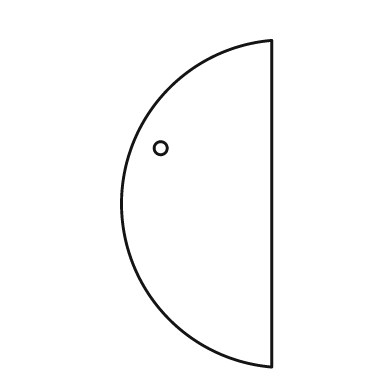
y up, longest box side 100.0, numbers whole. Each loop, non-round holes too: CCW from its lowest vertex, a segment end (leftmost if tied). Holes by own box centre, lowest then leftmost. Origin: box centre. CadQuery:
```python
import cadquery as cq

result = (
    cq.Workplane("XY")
    .moveTo(23.0, -50.0)
    .lineTo(23.0, 50.0)
    .threePointArc((-23.0, 0.0), (23.0, -50.0))
    .close()
    .moveTo(-11.0, 17.0)
    .circle(2.0)
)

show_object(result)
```